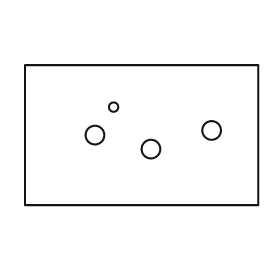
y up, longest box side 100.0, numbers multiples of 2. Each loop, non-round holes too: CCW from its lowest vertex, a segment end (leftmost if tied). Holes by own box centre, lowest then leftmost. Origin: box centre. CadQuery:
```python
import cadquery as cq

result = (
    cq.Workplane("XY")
    .moveTo(-50.0, -30.0)
    .lineTo(50.0, -30.0)
    .lineTo(50.0, 30.0)
    .lineTo(-50.0, 30.0)
    .close()
    .moveTo(4.0, -6.0)
    .circle(4.0)
    .moveTo(-20.0, 0.0)
    .circle(4.0)
    .moveTo(30.0, 2.0)
    .circle(4.0)
    .moveTo(-12.0, 12.0)
    .circle(2.0)
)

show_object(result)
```